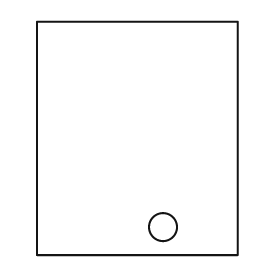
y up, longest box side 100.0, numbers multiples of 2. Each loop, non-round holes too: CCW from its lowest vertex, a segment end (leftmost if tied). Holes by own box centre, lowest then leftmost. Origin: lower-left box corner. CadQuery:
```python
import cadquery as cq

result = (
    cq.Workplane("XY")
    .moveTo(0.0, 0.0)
    .lineTo(86.0, 0.0)
    .lineTo(86.0, 100.0)
    .lineTo(0.0, 100.0)
    .close()
    .moveTo(54.0, 12.0)
    .circle(6.0)
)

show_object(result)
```